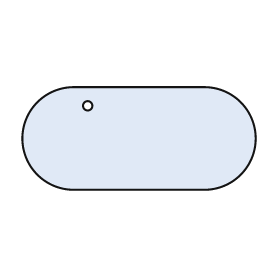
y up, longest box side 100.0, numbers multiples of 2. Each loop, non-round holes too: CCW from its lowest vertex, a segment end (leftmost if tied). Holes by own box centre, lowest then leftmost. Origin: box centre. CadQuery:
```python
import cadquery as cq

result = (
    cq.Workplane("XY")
    .moveTo(-28.0, -22.0)
    .lineTo(28.0, -22.0)
    .threePointArc((50.0, 0.0), (28.0, 22.0))
    .lineTo(-28.0, 22.0)
    .threePointArc((-50.0, 0.0), (-28.0, -22.0))
    .close()
    .moveTo(-22.0, 14.0)
    .circle(2.0)
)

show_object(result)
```